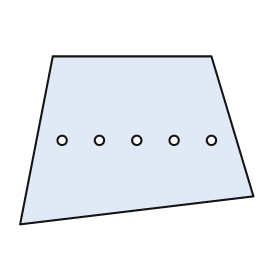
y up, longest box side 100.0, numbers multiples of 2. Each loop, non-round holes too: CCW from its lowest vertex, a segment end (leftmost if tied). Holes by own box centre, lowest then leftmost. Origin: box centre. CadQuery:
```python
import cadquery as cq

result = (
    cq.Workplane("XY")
    .moveTo(-50.0, -36.0)
    .lineTo(50.0, -24.0)
    .lineTo(32.0, 36.0)
    .lineTo(-36.0, 36.0)
    .close()
    .moveTo(-32.0, 0.0)
    .circle(2.0)
    .moveTo(-16.0, 0.0)
    .circle(2.0)
    .moveTo(0.0, 0.0)
    .circle(2.0)
    .moveTo(16.0, 0.0)
    .circle(2.0)
    .moveTo(32.0, 0.0)
    .circle(2.0)
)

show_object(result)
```